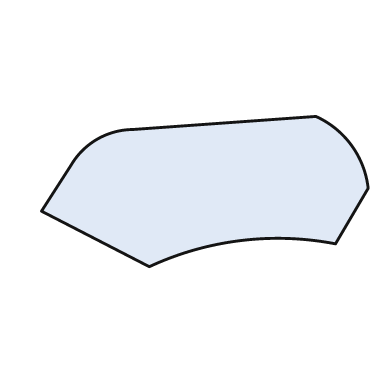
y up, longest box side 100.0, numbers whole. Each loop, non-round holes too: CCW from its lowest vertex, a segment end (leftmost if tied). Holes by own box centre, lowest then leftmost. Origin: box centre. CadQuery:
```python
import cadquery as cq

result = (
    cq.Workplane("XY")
    .moveTo(-17.0, -23.0)
    .threePointArc((11.0, -15.0), (40.0, -16.0))
    .lineTo(50.0, 1.0)
    .threePointArc((45.0, 14.0), (34.0, 23.0))
    .lineTo(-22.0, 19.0)
    .threePointArc((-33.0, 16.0), (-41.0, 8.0))
    .lineTo(-50.0, -6.0)
    .close()
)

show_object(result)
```